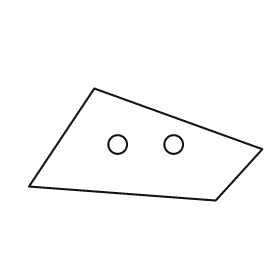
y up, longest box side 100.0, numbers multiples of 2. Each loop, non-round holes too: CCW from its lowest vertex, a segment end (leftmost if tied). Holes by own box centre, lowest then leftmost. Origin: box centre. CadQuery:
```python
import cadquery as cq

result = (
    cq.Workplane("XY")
    .moveTo(30.0, -24.0)
    .lineTo(50.0, -2.0)
    .lineTo(-22.0, 24.0)
    .lineTo(-50.0, -18.0)
    .close()
    .moveTo(-12.0, 0.0)
    .circle(4.0)
    .moveTo(12.0, 0.0)
    .circle(4.0)
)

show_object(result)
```